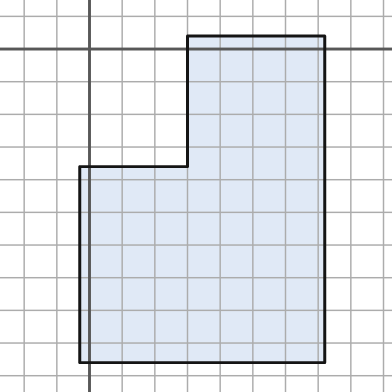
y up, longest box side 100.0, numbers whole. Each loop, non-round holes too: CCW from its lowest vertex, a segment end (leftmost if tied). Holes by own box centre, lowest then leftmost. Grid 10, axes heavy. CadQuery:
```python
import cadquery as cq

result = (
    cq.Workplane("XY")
    .moveTo(-3.0, -96.0)
    .lineTo(72.0, -96.0)
    .lineTo(72.0, 4.0)
    .lineTo(30.0, 4.0)
    .lineTo(30.0, -36.0)
    .lineTo(-3.0, -36.0)
    .close()
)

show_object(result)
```